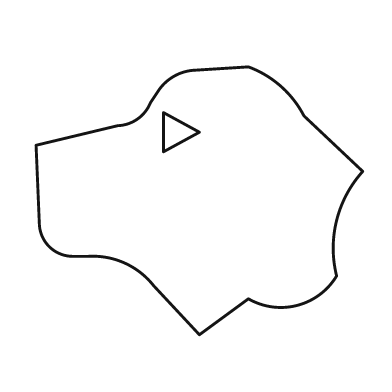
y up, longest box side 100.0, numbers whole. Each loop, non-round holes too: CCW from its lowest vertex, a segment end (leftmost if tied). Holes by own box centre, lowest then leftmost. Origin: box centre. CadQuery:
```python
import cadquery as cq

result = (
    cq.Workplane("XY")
    .moveTo(0.0, -41.0)
    .lineTo(15.0, -30.0)
    .threePointArc((30.0, -32.0), (42.0, -23.0))
    .threePointArc((42.0, -6.0), (50.0, 9.0))
    .lineTo(32.0, 26.0)
    .threePointArc((25.0, 35.0), (15.0, 41.0))
    .lineTo(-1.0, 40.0)
    .threePointArc((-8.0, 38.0), (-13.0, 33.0))
    .lineTo(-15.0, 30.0)
    .threePointArc((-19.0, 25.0), (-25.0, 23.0))
    .lineTo(-50.0, 17.0)
    .lineTo(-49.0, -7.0)
    .threePointArc((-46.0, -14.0), (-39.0, -17.0))
    .lineTo(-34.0, -17.0)
    .threePointArc((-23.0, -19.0), (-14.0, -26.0))
    .close()
    .moveTo(-11.0, 15.0)
    .lineTo(0.0, 21.0)
    .lineTo(-11.0, 27.0)
    .close()
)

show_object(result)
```